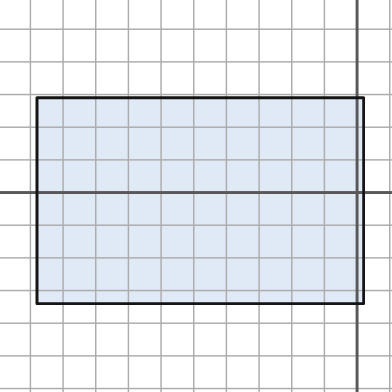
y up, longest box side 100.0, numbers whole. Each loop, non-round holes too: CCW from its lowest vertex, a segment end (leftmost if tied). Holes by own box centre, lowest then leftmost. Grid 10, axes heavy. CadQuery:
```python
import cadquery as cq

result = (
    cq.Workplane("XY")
    .moveTo(-98.0, -34.0)
    .lineTo(2.0, -34.0)
    .lineTo(2.0, 29.0)
    .lineTo(-98.0, 29.0)
    .close()
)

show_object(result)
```